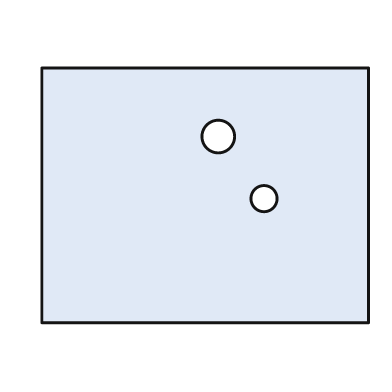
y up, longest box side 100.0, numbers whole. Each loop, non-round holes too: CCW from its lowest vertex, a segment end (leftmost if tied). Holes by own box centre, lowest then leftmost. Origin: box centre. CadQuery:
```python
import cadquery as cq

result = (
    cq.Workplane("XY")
    .moveTo(-50.0, -39.0)
    .lineTo(50.0, -39.0)
    .lineTo(50.0, 39.0)
    .lineTo(-50.0, 39.0)
    .close()
    .moveTo(18.0, -1.0)
    .circle(4.0)
    .moveTo(4.0, 18.0)
    .circle(5.0)
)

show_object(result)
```